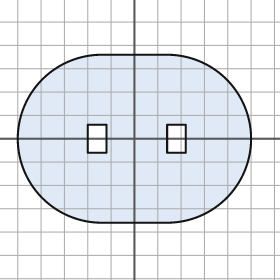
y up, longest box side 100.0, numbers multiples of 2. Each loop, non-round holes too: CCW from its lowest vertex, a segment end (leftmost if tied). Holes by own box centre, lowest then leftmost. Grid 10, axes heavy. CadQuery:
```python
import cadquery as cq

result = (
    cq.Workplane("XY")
    .moveTo(-14.0, -36.0)
    .lineTo(14.0, -36.0)
    .threePointArc((50.0, 0.0), (14.0, 36.0))
    .lineTo(-14.0, 36.0)
    .threePointArc((-50.0, 0.0), (-14.0, -36.0))
    .close()
    .moveTo(-20.0, -6.0)
    .lineTo(-12.0, -6.0)
    .lineTo(-12.0, 6.0)
    .lineTo(-20.0, 6.0)
    .close()
    .moveTo(14.0, -6.0)
    .lineTo(22.0, -6.0)
    .lineTo(22.0, 6.0)
    .lineTo(14.0, 6.0)
    .close()
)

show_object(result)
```